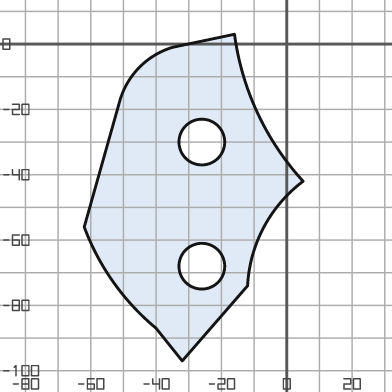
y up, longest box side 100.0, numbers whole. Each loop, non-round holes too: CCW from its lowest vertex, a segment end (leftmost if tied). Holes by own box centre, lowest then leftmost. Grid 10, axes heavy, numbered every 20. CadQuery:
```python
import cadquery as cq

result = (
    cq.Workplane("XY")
    .moveTo(-32.0, -97.0)
    .lineTo(-12.0, -74.0)
    .threePointArc((-7.0, -56.0), (5.0, -42.0))
    .threePointArc((-9.0, -21.0), (-16.0, 3.0))
    .lineTo(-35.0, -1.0)
    .threePointArc((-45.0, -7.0), (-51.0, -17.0))
    .lineTo(-62.0, -56.0)
    .threePointArc((-53.0, -73.0), (-40.0, -87.0))
    .close()
    .moveTo(-26.0, -68.0)
    .circle(7.0)
    .moveTo(-26.0, -30.0)
    .circle(7.0)
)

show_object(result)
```